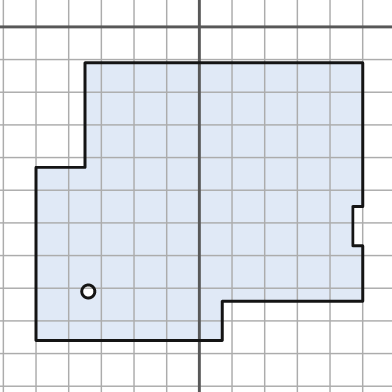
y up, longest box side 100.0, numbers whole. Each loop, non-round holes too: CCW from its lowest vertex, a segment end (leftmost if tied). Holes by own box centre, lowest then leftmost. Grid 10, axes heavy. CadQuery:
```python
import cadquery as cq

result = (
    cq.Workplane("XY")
    .moveTo(-50.0, -96.0)
    .lineTo(7.0, -96.0)
    .lineTo(7.0, -84.0)
    .lineTo(50.0, -84.0)
    .lineTo(50.0, -67.0)
    .lineTo(47.0, -67.0)
    .lineTo(47.0, -55.0)
    .lineTo(50.0, -55.0)
    .lineTo(50.0, -11.0)
    .lineTo(-35.0, -11.0)
    .lineTo(-35.0, -43.0)
    .lineTo(-50.0, -43.0)
    .close()
    .moveTo(-34.0, -81.0)
    .circle(2.0)
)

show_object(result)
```